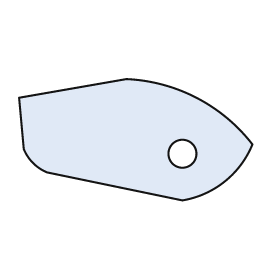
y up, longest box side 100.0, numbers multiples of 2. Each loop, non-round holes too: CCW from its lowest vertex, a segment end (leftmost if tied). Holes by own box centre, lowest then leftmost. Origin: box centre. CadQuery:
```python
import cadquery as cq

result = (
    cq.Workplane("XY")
    .moveTo(20.0, -26.0)
    .threePointArc((38.0, -18.0), (50.0, -2.0))
    .threePointArc((26.0, 18.0), (-4.0, 26.0))
    .lineTo(-50.0, 18.0)
    .lineTo(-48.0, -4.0)
    .threePointArc((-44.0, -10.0), (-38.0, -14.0))
    .close()
    .moveTo(20.0, -6.0)
    .circle(6.0)
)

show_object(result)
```